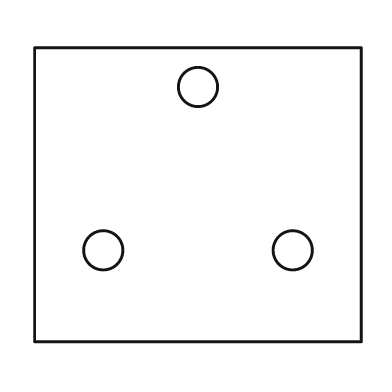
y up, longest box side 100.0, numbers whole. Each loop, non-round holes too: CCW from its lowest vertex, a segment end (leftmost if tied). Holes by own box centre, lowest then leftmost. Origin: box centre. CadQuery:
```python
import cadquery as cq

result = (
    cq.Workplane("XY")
    .moveTo(-50.0, -45.0)
    .lineTo(50.0, -45.0)
    .lineTo(50.0, 45.0)
    .lineTo(-50.0, 45.0)
    .close()
    .moveTo(-29.0, -17.0)
    .circle(6.0)
    .moveTo(29.0, -17.0)
    .circle(6.0)
    .moveTo(0.0, 33.0)
    .circle(6.0)
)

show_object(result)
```